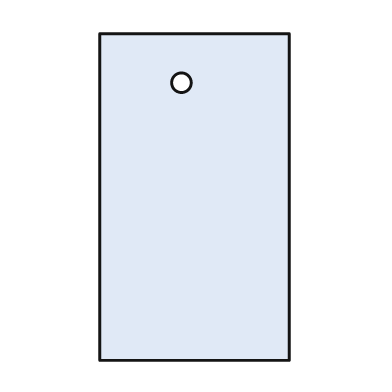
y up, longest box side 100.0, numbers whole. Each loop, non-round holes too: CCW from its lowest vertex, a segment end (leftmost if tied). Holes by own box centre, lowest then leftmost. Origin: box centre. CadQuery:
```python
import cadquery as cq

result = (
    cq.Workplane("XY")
    .moveTo(-29.0, -50.0)
    .lineTo(29.0, -50.0)
    .lineTo(29.0, 50.0)
    .lineTo(-29.0, 50.0)
    .close()
    .moveTo(-4.0, 35.0)
    .circle(3.0)
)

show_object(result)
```